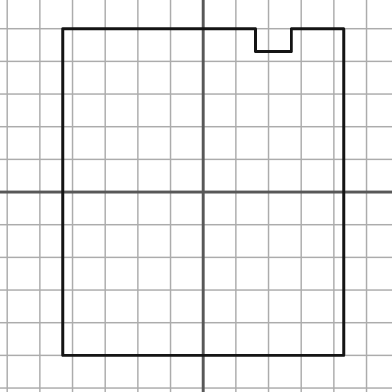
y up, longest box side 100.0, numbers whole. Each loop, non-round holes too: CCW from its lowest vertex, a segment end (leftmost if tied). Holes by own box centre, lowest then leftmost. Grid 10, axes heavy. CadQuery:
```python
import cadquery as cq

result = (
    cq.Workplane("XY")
    .moveTo(-43.0, -50.0)
    .lineTo(43.0, -50.0)
    .lineTo(43.0, 50.0)
    .lineTo(27.0, 50.0)
    .lineTo(27.0, 43.0)
    .lineTo(16.0, 43.0)
    .lineTo(16.0, 50.0)
    .lineTo(-43.0, 50.0)
    .close()
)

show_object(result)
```